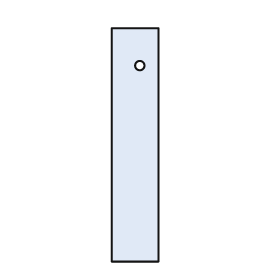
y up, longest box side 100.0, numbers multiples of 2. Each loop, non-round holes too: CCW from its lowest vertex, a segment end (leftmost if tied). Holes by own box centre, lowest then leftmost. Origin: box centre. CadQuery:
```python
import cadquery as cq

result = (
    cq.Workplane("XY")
    .moveTo(-10.0, -50.0)
    .lineTo(10.0, -50.0)
    .lineTo(10.0, 50.0)
    .lineTo(-10.0, 50.0)
    .close()
    .moveTo(2.0, 34.0)
    .circle(2.0)
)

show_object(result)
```